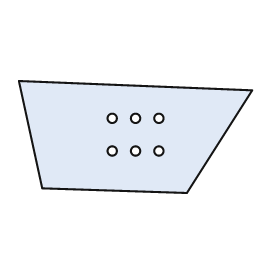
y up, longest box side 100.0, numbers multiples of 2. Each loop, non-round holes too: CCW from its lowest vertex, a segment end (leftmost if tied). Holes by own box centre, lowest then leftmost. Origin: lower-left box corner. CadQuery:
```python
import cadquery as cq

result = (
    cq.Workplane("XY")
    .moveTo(72.0, 0.0)
    .lineTo(100.0, 44.0)
    .lineTo(0.0, 48.0)
    .lineTo(10.0, 2.0)
    .close()
    .moveTo(40.0, 18.0)
    .circle(2.0)
    .moveTo(50.0, 18.0)
    .circle(2.0)
    .moveTo(60.0, 18.0)
    .circle(2.0)
    .moveTo(40.0, 32.0)
    .circle(2.0)
    .moveTo(50.0, 32.0)
    .circle(2.0)
    .moveTo(60.0, 32.0)
    .circle(2.0)
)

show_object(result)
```